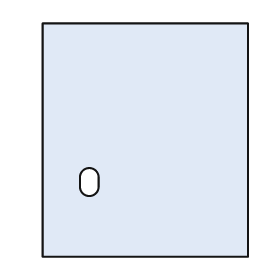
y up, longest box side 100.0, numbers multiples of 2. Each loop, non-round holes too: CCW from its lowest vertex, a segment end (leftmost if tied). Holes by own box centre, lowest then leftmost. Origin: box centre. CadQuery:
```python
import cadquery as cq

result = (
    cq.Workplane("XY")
    .moveTo(-44.0, -50.0)
    .lineTo(44.0, -50.0)
    .lineTo(44.0, 50.0)
    .lineTo(-44.0, 50.0)
    .close()
    .moveTo(-28.0, -20.0)
    .threePointArc((-24.0, -24.0), (-20.0, -20.0))
    .lineTo(-20.0, -16.0)
    .threePointArc((-24.0, -12.0), (-28.0, -16.0))
    .close()
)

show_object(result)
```